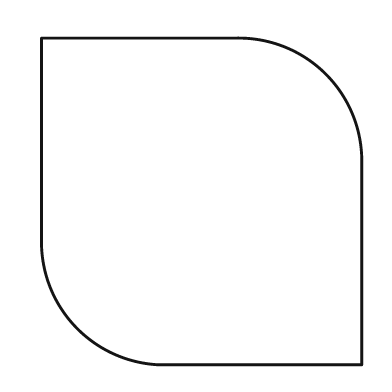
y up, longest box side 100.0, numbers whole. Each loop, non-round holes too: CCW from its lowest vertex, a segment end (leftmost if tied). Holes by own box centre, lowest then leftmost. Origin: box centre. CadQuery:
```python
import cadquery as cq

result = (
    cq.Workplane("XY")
    .moveTo(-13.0, -50.0)
    .lineTo(49.0, -50.0)
    .lineTo(49.0, 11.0)
    .threePointArc((38.0, 39.0), (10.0, 50.0))
    .lineTo(-49.0, 50.0)
    .lineTo(-49.0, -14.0)
    .threePointArc((-38.0, -39.0), (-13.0, -50.0))
    .close()
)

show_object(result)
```